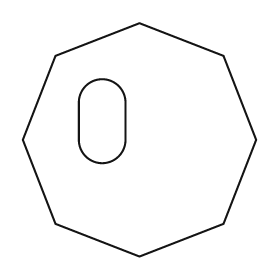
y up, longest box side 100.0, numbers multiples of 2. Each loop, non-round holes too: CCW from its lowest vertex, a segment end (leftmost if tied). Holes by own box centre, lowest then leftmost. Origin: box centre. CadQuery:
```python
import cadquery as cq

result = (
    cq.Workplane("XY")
    .moveTo(0.0, -50.0)
    .lineTo(36.0, -36.0)
    .lineTo(50.0, 0.0)
    .lineTo(36.0, 36.0)
    .lineTo(0.0, 50.0)
    .lineTo(-36.0, 36.0)
    .lineTo(-50.0, 0.0)
    .lineTo(-36.0, -36.0)
    .close()
    .moveTo(-26.0, 0.0)
    .threePointArc((-16.0, -10.0), (-6.0, 0.0))
    .lineTo(-6.0, 16.0)
    .threePointArc((-16.0, 26.0), (-26.0, 16.0))
    .close()
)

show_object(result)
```